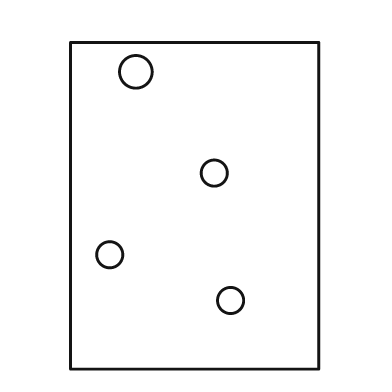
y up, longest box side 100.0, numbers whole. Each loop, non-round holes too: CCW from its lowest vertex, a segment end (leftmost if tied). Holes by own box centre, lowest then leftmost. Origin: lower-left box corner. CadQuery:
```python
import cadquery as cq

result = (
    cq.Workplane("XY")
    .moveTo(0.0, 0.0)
    .lineTo(76.0, 0.0)
    .lineTo(76.0, 100.0)
    .lineTo(0.0, 100.0)
    .close()
    .moveTo(49.0, 21.0)
    .circle(4.0)
    .moveTo(12.0, 35.0)
    .circle(4.0)
    .moveTo(44.0, 60.0)
    .circle(4.0)
    .moveTo(20.0, 91.0)
    .circle(5.0)
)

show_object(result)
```